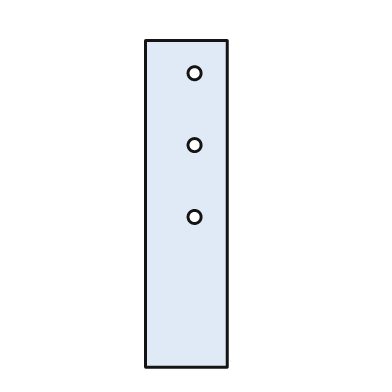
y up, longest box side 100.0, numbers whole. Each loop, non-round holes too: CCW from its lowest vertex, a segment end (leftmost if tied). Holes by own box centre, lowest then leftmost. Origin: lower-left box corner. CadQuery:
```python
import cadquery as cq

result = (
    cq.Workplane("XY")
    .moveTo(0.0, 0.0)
    .lineTo(25.0, 0.0)
    .lineTo(25.0, 100.0)
    .lineTo(0.0, 100.0)
    .close()
    .moveTo(15.0, 46.0)
    .circle(2.0)
    .moveTo(15.0, 68.0)
    .circle(2.0)
    .moveTo(15.0, 90.0)
    .circle(2.0)
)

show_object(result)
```